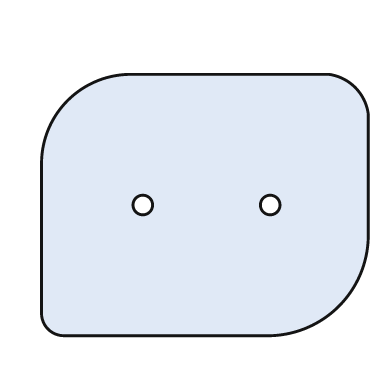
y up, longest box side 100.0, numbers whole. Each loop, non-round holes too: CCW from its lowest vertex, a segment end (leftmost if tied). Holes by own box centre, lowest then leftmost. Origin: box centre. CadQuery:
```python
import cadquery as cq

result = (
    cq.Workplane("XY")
    .moveTo(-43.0, -40.0)
    .lineTo(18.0, -40.0)
    .threePointArc((41.0, -31.0), (50.0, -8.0))
    .lineTo(50.0, 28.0)
    .threePointArc((46.0, 36.0), (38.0, 40.0))
    .lineTo(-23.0, 40.0)
    .threePointArc((-42.0, 32.0), (-50.0, 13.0))
    .lineTo(-50.0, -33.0)
    .threePointArc((-48.0, -38.0), (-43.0, -40.0))
    .close()
    .moveTo(-19.0, 0.0)
    .circle(3.0)
    .moveTo(20.0, 0.0)
    .circle(3.0)
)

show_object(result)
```